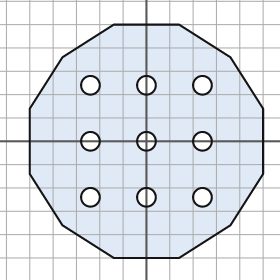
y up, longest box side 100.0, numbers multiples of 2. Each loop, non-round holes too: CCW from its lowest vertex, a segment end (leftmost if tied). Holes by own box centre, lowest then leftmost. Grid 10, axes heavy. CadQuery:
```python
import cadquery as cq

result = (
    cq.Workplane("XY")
    .moveTo(-14.0, -50.0)
    .lineTo(14.0, -50.0)
    .lineTo(36.0, -36.0)
    .lineTo(50.0, -14.0)
    .lineTo(50.0, 14.0)
    .lineTo(36.0, 36.0)
    .lineTo(14.0, 50.0)
    .lineTo(-14.0, 50.0)
    .lineTo(-36.0, 36.0)
    .lineTo(-50.0, 14.0)
    .lineTo(-50.0, -14.0)
    .lineTo(-36.0, -36.0)
    .close()
    .moveTo(-24.0, -24.0)
    .circle(4.0)
    .moveTo(0.0, -24.0)
    .circle(4.0)
    .moveTo(24.0, -24.0)
    .circle(4.0)
    .moveTo(-24.0, 0.0)
    .circle(4.0)
    .moveTo(0.0, 0.0)
    .circle(4.0)
    .moveTo(24.0, 0.0)
    .circle(4.0)
    .moveTo(-24.0, 24.0)
    .circle(4.0)
    .moveTo(0.0, 24.0)
    .circle(4.0)
    .moveTo(24.0, 24.0)
    .circle(4.0)
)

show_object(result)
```